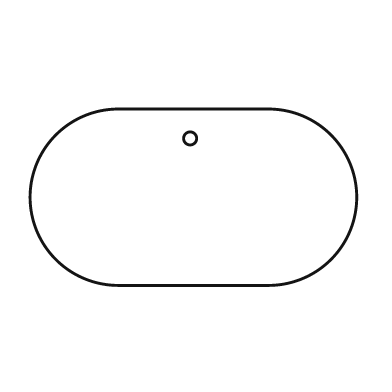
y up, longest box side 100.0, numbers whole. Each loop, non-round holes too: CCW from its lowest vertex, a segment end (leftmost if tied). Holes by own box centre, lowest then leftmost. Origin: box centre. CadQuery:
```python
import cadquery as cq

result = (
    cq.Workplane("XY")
    .moveTo(-23.0, -27.0)
    .lineTo(23.0, -27.0)
    .threePointArc((50.0, 0.0), (23.0, 27.0))
    .lineTo(-23.0, 27.0)
    .threePointArc((-50.0, 0.0), (-23.0, -27.0))
    .close()
    .moveTo(-1.0, 18.0)
    .circle(2.0)
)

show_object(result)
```